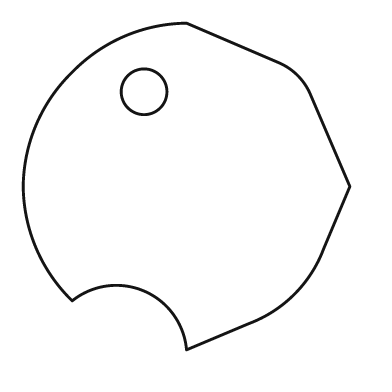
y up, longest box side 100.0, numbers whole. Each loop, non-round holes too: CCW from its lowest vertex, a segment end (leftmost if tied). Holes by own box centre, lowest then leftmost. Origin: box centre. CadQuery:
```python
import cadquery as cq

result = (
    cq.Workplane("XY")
    .moveTo(0.0, -50.0)
    .lineTo(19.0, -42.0)
    .threePointArc((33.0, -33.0), (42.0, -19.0))
    .lineTo(50.0, 0.0)
    .lineTo(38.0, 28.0)
    .threePointArc((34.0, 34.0), (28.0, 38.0))
    .lineTo(0.0, 50.0)
    .threePointArc((-19.0, 46.0), (-35.0, 35.0))
    .threePointArc((-46.0, 19.0), (-50.0, 0.0))
    .threePointArc((-46.0, -19.0), (-35.0, -35.0))
    .threePointArc((-13.0, -32.0), (0.0, -50.0))
    .close()
    .moveTo(-13.0, 29.0)
    .circle(7.0)
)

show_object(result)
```